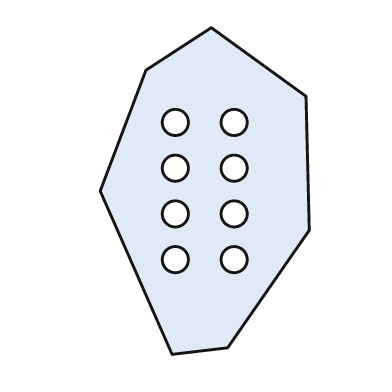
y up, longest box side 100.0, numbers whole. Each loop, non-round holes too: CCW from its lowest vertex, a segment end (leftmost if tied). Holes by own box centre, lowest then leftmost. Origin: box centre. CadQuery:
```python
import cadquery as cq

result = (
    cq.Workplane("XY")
    .moveTo(-10.0, -50.0)
    .lineTo(7.0, -48.0)
    .lineTo(32.0, -12.0)
    .lineTo(31.0, 29.0)
    .lineTo(2.0, 50.0)
    .lineTo(-18.0, 37.0)
    .lineTo(-32.0, 0.0)
    .close()
    .moveTo(-9.0, -21.0)
    .circle(4.0)
    .moveTo(9.0, -21.0)
    .circle(4.0)
    .moveTo(-9.0, -7.0)
    .circle(4.0)
    .moveTo(9.0, -7.0)
    .circle(4.0)
    .moveTo(-9.0, 7.0)
    .circle(4.0)
    .moveTo(9.0, 7.0)
    .circle(4.0)
    .moveTo(-9.0, 21.0)
    .circle(4.0)
    .moveTo(9.0, 21.0)
    .circle(4.0)
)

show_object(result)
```